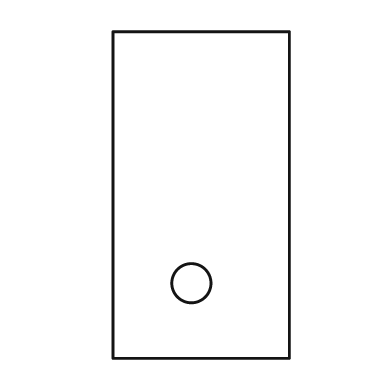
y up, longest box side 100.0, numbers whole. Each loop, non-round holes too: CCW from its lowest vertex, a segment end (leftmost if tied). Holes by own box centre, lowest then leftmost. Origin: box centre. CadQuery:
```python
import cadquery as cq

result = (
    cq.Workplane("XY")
    .moveTo(-27.0, -50.0)
    .lineTo(27.0, -50.0)
    .lineTo(27.0, 50.0)
    .lineTo(-27.0, 50.0)
    .close()
    .moveTo(-3.0, -27.0)
    .circle(6.0)
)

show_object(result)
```